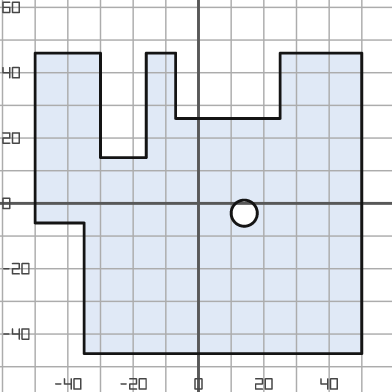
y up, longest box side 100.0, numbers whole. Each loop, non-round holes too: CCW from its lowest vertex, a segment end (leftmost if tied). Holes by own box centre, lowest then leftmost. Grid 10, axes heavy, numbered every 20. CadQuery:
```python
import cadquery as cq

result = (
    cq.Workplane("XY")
    .moveTo(-35.0, -46.0)
    .lineTo(50.0, -46.0)
    .lineTo(50.0, 46.0)
    .lineTo(25.0, 46.0)
    .lineTo(25.0, 26.0)
    .lineTo(-7.0, 26.0)
    .lineTo(-7.0, 46.0)
    .lineTo(-16.0, 46.0)
    .lineTo(-16.0, 14.0)
    .lineTo(-30.0, 14.0)
    .lineTo(-30.0, 46.0)
    .lineTo(-50.0, 46.0)
    .lineTo(-50.0, -6.0)
    .lineTo(-35.0, -6.0)
    .close()
    .moveTo(14.0, -3.0)
    .circle(4.0)
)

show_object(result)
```